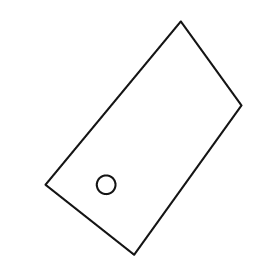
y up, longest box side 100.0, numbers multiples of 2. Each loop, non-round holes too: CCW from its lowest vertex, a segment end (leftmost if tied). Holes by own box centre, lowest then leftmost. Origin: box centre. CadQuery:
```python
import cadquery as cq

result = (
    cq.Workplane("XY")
    .moveTo(-4.0, -50.0)
    .lineTo(42.0, 14.0)
    .lineTo(16.0, 50.0)
    .lineTo(-42.0, -20.0)
    .close()
    .moveTo(-16.0, -20.0)
    .circle(4.0)
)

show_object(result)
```